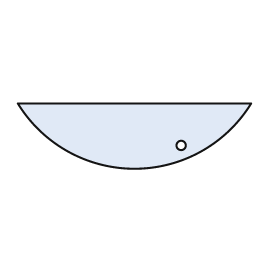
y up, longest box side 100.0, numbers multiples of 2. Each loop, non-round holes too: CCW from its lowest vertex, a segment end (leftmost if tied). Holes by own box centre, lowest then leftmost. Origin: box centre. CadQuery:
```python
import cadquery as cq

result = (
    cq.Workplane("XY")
    .moveTo(-50.0, 14.0)
    .threePointArc((0.0, -14.0), (50.0, 14.0))
    .close()
    .moveTo(20.0, -4.0)
    .circle(2.0)
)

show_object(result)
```